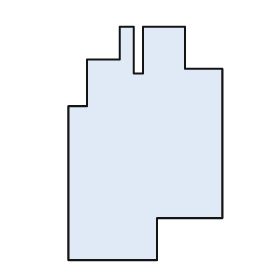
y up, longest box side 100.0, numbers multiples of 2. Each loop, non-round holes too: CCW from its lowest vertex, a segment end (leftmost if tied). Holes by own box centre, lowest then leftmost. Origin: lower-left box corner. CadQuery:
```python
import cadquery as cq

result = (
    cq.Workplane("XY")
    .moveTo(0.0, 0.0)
    .lineTo(38.0, 0.0)
    .lineTo(38.0, 18.0)
    .lineTo(66.0, 18.0)
    .lineTo(66.0, 82.0)
    .lineTo(50.0, 82.0)
    .lineTo(50.0, 100.0)
    .lineTo(32.0, 100.0)
    .lineTo(32.0, 80.0)
    .lineTo(28.0, 80.0)
    .lineTo(28.0, 100.0)
    .lineTo(22.0, 100.0)
    .lineTo(22.0, 86.0)
    .lineTo(8.0, 86.0)
    .lineTo(8.0, 66.0)
    .lineTo(0.0, 66.0)
    .close()
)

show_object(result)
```